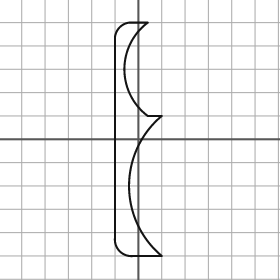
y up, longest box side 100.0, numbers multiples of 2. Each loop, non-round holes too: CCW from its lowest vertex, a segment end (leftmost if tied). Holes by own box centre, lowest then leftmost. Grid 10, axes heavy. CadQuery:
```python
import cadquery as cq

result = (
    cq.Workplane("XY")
    .moveTo(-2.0, -50.0)
    .lineTo(10.0, -50.0)
    .threePointArc((-4.0, -20.0), (10.0, 10.0))
    .lineTo(4.0, 10.0)
    .threePointArc((-6.0, 30.0), (4.0, 50.0))
    .lineTo(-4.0, 50.0)
    .threePointArc((-8.0, 48.0), (-10.0, 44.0))
    .lineTo(-10.0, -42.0)
    .threePointArc((-8.0, -48.0), (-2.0, -50.0))
    .close()
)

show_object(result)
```